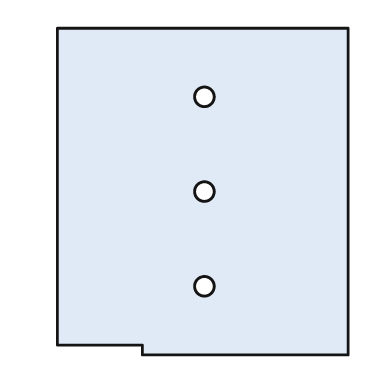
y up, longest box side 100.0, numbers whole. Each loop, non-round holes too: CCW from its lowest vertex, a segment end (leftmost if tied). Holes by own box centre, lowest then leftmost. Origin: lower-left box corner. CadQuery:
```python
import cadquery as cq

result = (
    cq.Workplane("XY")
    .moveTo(26.0, 0.0)
    .lineTo(89.0, 0.0)
    .lineTo(89.0, 100.0)
    .lineTo(0.0, 100.0)
    .lineTo(0.0, 3.0)
    .lineTo(26.0, 3.0)
    .close()
    .moveTo(45.0, 21.0)
    .circle(3.0)
    .moveTo(45.0, 50.0)
    .circle(3.0)
    .moveTo(45.0, 79.0)
    .circle(3.0)
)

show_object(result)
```